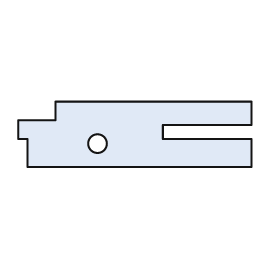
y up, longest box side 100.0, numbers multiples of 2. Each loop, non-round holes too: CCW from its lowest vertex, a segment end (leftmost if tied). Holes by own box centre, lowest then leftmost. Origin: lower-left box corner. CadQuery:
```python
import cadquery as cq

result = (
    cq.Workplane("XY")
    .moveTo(4.0, 0.0)
    .lineTo(100.0, 0.0)
    .lineTo(100.0, 12.0)
    .lineTo(62.0, 12.0)
    .lineTo(62.0, 18.0)
    .lineTo(100.0, 18.0)
    .lineTo(100.0, 28.0)
    .lineTo(16.0, 28.0)
    .lineTo(16.0, 20.0)
    .lineTo(0.0, 20.0)
    .lineTo(0.0, 12.0)
    .lineTo(4.0, 12.0)
    .close()
    .moveTo(34.0, 10.0)
    .circle(4.0)
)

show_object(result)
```